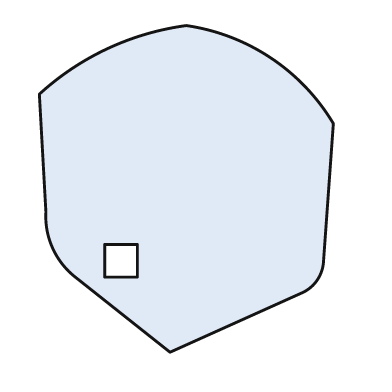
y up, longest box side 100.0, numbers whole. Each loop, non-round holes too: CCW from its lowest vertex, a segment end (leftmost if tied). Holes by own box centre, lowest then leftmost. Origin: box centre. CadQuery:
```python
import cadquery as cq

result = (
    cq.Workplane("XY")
    .moveTo(-5.0, -50.0)
    .lineTo(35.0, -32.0)
    .threePointArc((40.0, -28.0), (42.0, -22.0))
    .lineTo(45.0, 20.0)
    .threePointArc((26.0, 40.0), (0.0, 50.0))
    .threePointArc((-24.0, 43.0), (-45.0, 29.0))
    .lineTo(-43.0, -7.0)
    .threePointArc((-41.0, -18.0), (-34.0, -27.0))
    .close()
    .moveTo(-25.0, -27.0)
    .lineTo(-15.0, -27.0)
    .lineTo(-15.0, -17.0)
    .lineTo(-25.0, -17.0)
    .close()
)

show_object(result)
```